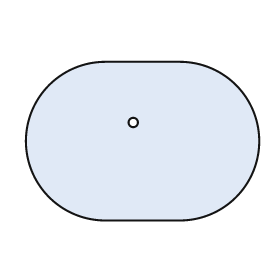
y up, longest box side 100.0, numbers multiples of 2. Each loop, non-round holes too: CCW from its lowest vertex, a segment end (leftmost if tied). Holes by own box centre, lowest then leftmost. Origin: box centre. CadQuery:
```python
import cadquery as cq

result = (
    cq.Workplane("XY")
    .moveTo(-16.0, -34.0)
    .lineTo(16.0, -34.0)
    .threePointArc((50.0, 0.0), (16.0, 34.0))
    .lineTo(-16.0, 34.0)
    .threePointArc((-50.0, 0.0), (-16.0, -34.0))
    .close()
    .moveTo(-4.0, 8.0)
    .circle(2.0)
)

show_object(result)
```